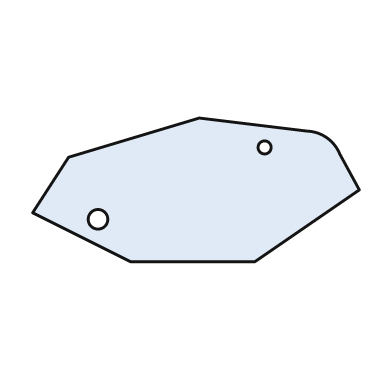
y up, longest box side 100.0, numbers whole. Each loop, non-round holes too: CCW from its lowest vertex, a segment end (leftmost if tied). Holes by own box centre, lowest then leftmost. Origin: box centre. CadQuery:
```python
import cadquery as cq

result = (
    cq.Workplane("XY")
    .moveTo(-20.0, -22.0)
    .lineTo(18.0, -22.0)
    .lineTo(50.0, 0.0)
    .lineTo(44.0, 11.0)
    .threePointArc((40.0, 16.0), (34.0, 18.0))
    .lineTo(1.0, 22.0)
    .lineTo(-39.0, 10.0)
    .lineTo(-50.0, -7.0)
    .close()
    .moveTo(-30.0, -9.0)
    .circle(3.0)
    .moveTo(21.0, 13.0)
    .circle(2.0)
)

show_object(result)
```